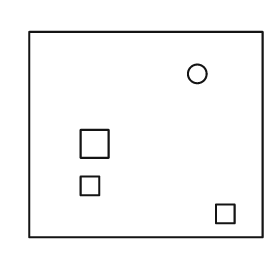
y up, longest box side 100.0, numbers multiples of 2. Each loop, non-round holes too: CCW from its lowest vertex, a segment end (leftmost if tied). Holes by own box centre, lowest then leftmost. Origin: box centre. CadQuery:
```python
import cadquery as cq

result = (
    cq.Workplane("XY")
    .moveTo(-50.0, -44.0)
    .lineTo(50.0, -44.0)
    .lineTo(50.0, 44.0)
    .lineTo(-50.0, 44.0)
    .close()
    .moveTo(30.0, -38.0)
    .lineTo(38.0, -38.0)
    .lineTo(38.0, -30.0)
    .lineTo(30.0, -30.0)
    .close()
    .moveTo(-28.0, -26.0)
    .lineTo(-20.0, -26.0)
    .lineTo(-20.0, -18.0)
    .lineTo(-28.0, -18.0)
    .close()
    .moveTo(-28.0, -10.0)
    .lineTo(-16.0, -10.0)
    .lineTo(-16.0, 2.0)
    .lineTo(-28.0, 2.0)
    .close()
    .moveTo(22.0, 26.0)
    .circle(4.0)
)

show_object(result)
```